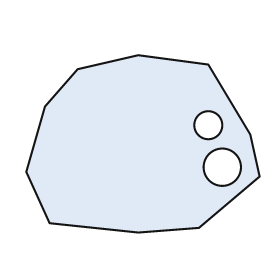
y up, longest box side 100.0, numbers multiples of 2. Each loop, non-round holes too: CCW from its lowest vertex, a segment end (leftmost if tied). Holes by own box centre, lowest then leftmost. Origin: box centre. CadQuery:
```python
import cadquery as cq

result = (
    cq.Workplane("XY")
    .moveTo(-2.0, -38.0)
    .lineTo(24.0, -36.0)
    .lineTo(50.0, -14.0)
    .lineTo(46.0, 4.0)
    .lineTo(28.0, 34.0)
    .lineTo(-2.0, 38.0)
    .lineTo(-28.0, 32.0)
    .lineTo(-42.0, 16.0)
    .lineTo(-50.0, -12.0)
    .lineTo(-40.0, -34.0)
    .close()
    .moveTo(34.0, -10.0)
    .circle(8.0)
    .moveTo(28.0, 8.0)
    .circle(6.0)
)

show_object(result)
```